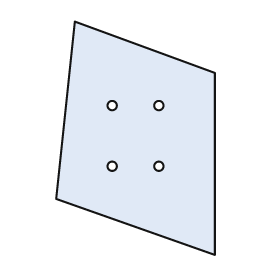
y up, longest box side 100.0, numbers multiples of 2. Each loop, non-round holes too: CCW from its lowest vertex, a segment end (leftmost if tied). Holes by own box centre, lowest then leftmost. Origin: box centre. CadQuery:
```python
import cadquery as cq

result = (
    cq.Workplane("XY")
    .moveTo(34.0, -50.0)
    .lineTo(34.0, 28.0)
    .lineTo(-26.0, 50.0)
    .lineTo(-34.0, -26.0)
    .close()
    .moveTo(-10.0, -12.0)
    .circle(2.0)
    .moveTo(10.0, -12.0)
    .circle(2.0)
    .moveTo(-10.0, 14.0)
    .circle(2.0)
    .moveTo(10.0, 14.0)
    .circle(2.0)
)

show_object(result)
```